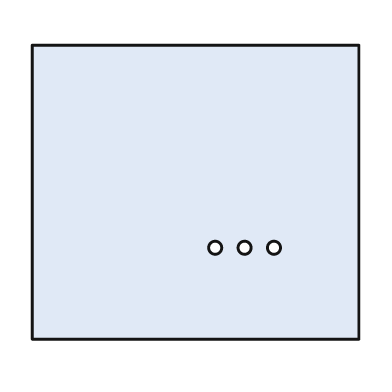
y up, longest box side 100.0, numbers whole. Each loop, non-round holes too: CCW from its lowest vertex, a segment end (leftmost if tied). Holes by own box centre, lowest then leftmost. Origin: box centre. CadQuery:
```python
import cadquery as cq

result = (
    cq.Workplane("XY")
    .moveTo(-50.0, -45.0)
    .lineTo(50.0, -45.0)
    .lineTo(50.0, 45.0)
    .lineTo(-50.0, 45.0)
    .close()
    .moveTo(6.0, -17.0)
    .circle(2.0)
    .moveTo(15.0, -17.0)
    .circle(2.0)
    .moveTo(24.0, -17.0)
    .circle(2.0)
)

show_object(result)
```